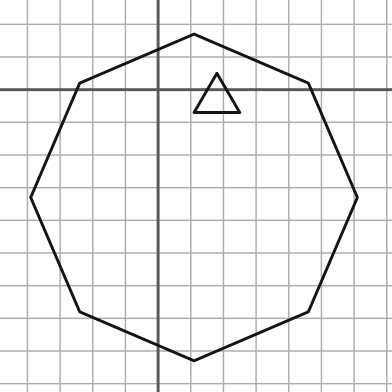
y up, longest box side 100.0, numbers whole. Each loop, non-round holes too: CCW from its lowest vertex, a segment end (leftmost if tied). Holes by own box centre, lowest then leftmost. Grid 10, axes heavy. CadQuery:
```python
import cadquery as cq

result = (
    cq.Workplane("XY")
    .moveTo(11.0, -83.0)
    .lineTo(46.0, -68.0)
    .lineTo(61.0, -33.0)
    .lineTo(46.0, 2.0)
    .lineTo(11.0, 17.0)
    .lineTo(-24.0, 2.0)
    .lineTo(-39.0, -33.0)
    .lineTo(-24.0, -68.0)
    .close()
    .moveTo(11.0, -7.0)
    .lineTo(25.0, -7.0)
    .lineTo(18.0, 5.0)
    .close()
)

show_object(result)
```